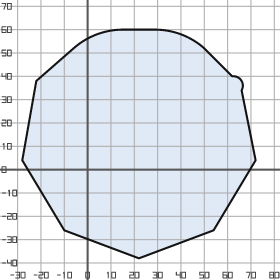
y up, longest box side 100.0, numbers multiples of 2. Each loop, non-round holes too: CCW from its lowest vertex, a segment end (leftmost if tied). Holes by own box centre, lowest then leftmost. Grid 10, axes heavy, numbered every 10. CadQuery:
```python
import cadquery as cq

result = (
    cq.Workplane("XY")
    .moveTo(22.0, -38.0)
    .lineTo(54.0, -26.0)
    .lineTo(72.0, 4.0)
    .lineTo(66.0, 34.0)
    .threePointArc((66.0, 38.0), (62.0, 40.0))
    .lineTo(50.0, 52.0)
    .threePointArc((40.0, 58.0), (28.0, 60.0))
    .lineTo(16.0, 60.0)
    .threePointArc((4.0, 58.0), (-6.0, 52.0))
    .lineTo(-22.0, 38.0)
    .lineTo(-28.0, 4.0)
    .lineTo(-10.0, -26.0)
    .close()
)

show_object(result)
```